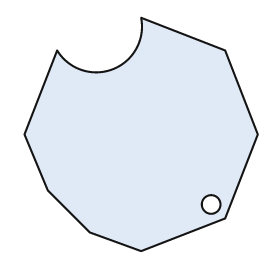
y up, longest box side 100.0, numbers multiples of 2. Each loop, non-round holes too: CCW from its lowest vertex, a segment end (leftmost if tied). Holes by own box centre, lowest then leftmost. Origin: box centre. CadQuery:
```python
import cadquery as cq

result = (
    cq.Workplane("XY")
    .moveTo(0.0, -50.0)
    .lineTo(36.0, -36.0)
    .lineTo(50.0, 0.0)
    .lineTo(36.0, 36.0)
    .lineTo(0.0, 50.0)
    .threePointArc((-12.0, 28.0), (-36.0, 36.0))
    .lineTo(-50.0, 0.0)
    .lineTo(-40.0, -24.0)
    .lineTo(-22.0, -42.0)
    .close()
    .moveTo(30.0, -30.0)
    .circle(4.0)
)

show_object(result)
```